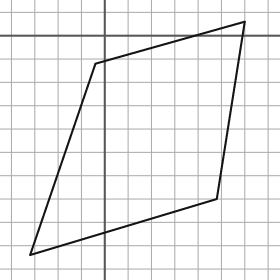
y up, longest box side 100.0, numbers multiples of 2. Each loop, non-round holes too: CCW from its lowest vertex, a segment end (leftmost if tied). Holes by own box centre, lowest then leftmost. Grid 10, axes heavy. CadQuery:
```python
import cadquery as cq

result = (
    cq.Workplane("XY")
    .moveTo(-32.0, -94.0)
    .lineTo(48.0, -70.0)
    .lineTo(60.0, 6.0)
    .lineTo(-4.0, -12.0)
    .close()
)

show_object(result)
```